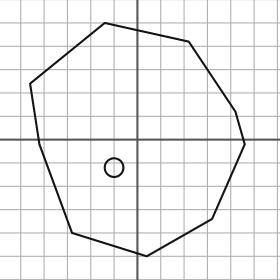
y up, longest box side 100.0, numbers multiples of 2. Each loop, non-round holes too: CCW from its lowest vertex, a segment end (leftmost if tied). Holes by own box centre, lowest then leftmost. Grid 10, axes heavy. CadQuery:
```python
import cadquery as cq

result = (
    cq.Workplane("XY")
    .moveTo(4.0, -50.0)
    .lineTo(32.0, -34.0)
    .lineTo(46.0, -2.0)
    .lineTo(42.0, 12.0)
    .lineTo(22.0, 42.0)
    .lineTo(-14.0, 50.0)
    .lineTo(-46.0, 24.0)
    .lineTo(-42.0, -2.0)
    .lineTo(-28.0, -40.0)
    .close()
    .moveTo(-10.0, -12.0)
    .circle(4.0)
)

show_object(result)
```